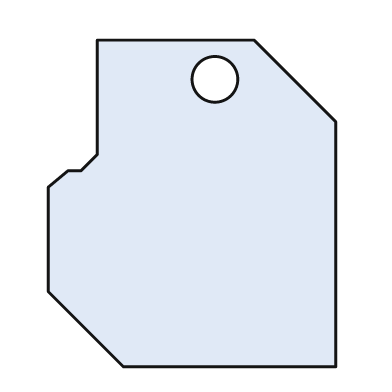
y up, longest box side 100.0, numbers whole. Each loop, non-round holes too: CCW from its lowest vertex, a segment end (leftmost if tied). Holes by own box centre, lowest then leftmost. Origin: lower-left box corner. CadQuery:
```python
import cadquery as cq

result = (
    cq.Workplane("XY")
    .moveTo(23.0, 0.0)
    .lineTo(88.0, 0.0)
    .lineTo(88.0, 75.0)
    .lineTo(63.0, 100.0)
    .lineTo(15.0, 100.0)
    .lineTo(15.0, 65.0)
    .lineTo(10.0, 60.0)
    .lineTo(6.0, 60.0)
    .lineTo(0.0, 55.0)
    .lineTo(0.0, 23.0)
    .close()
    .moveTo(51.0, 88.0)
    .circle(7.0)
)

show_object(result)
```